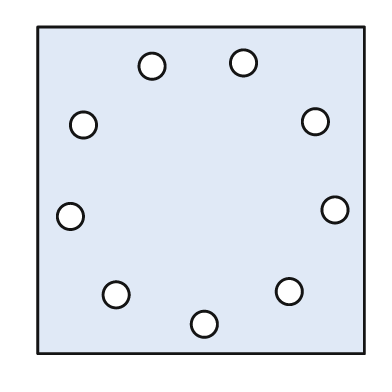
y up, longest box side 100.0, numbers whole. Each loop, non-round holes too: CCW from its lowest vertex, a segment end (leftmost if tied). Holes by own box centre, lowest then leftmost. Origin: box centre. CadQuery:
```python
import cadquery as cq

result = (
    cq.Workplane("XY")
    .moveTo(-50.0, -50.0)
    .lineTo(50.0, -50.0)
    .lineTo(50.0, 50.0)
    .lineTo(-50.0, 50.0)
    .close()
    .moveTo(1.0, -41.0)
    .circle(4.0)
    .moveTo(-26.0, -32.0)
    .circle(4.0)
    .moveTo(27.0, -31.0)
    .circle(4.0)
    .moveTo(-40.0, -8.0)
    .circle(4.0)
    .moveTo(41.0, -6.0)
    .circle(4.0)
    .moveTo(-36.0, 20.0)
    .circle(4.0)
    .moveTo(35.0, 21.0)
    .circle(4.0)
    .moveTo(-15.0, 38.0)
    .circle(4.0)
    .moveTo(13.0, 39.0)
    .circle(4.0)
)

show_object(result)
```